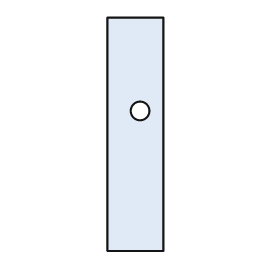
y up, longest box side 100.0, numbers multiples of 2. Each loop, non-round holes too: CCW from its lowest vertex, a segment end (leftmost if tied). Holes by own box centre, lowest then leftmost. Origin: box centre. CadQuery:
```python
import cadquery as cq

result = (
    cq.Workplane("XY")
    .moveTo(-12.0, -50.0)
    .lineTo(12.0, -50.0)
    .lineTo(12.0, 50.0)
    .lineTo(-12.0, 50.0)
    .close()
    .moveTo(2.0, 10.0)
    .circle(4.0)
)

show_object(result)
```